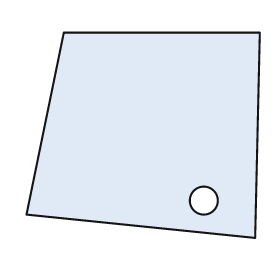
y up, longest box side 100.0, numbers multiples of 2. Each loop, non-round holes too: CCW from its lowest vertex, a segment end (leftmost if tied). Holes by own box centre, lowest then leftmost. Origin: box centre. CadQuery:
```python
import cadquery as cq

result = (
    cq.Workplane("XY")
    .moveTo(48.0, -44.0)
    .lineTo(50.0, 44.0)
    .lineTo(-34.0, 44.0)
    .lineTo(-50.0, -34.0)
    .close()
    .moveTo(26.0, -28.0)
    .circle(6.0)
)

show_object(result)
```